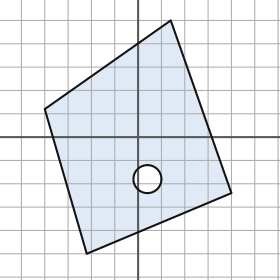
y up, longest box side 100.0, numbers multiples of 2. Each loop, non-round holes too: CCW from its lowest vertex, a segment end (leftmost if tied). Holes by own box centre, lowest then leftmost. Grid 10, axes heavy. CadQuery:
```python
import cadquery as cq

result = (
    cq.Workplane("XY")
    .moveTo(-22.0, -50.0)
    .lineTo(40.0, -24.0)
    .lineTo(14.0, 50.0)
    .lineTo(-40.0, 12.0)
    .close()
    .moveTo(4.0, -18.0)
    .circle(6.0)
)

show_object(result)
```